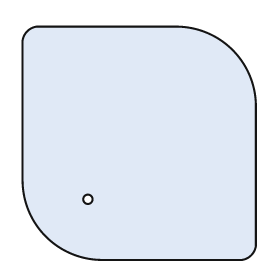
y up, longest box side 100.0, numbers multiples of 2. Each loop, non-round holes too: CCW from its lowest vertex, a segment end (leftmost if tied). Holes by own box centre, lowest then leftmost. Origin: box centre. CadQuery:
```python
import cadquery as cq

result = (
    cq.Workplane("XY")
    .moveTo(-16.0, -50.0)
    .lineTo(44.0, -50.0)
    .threePointArc((48.0, -48.0), (50.0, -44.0))
    .lineTo(50.0, 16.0)
    .threePointArc((40.0, 40.0), (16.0, 50.0))
    .lineTo(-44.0, 50.0)
    .threePointArc((-48.0, 48.0), (-50.0, 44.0))
    .lineTo(-50.0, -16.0)
    .threePointArc((-40.0, -40.0), (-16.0, -50.0))
    .close()
    .moveTo(-22.0, -24.0)
    .circle(2.0)
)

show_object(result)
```